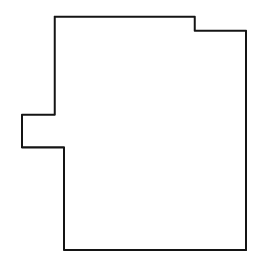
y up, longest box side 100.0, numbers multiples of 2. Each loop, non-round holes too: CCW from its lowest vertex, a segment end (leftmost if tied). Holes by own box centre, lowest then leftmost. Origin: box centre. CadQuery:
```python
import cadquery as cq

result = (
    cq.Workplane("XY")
    .moveTo(-30.0, -50.0)
    .lineTo(48.0, -50.0)
    .lineTo(48.0, 44.0)
    .lineTo(26.0, 44.0)
    .lineTo(26.0, 50.0)
    .lineTo(-34.0, 50.0)
    .lineTo(-34.0, 8.0)
    .lineTo(-48.0, 8.0)
    .lineTo(-48.0, -6.0)
    .lineTo(-30.0, -6.0)
    .close()
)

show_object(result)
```